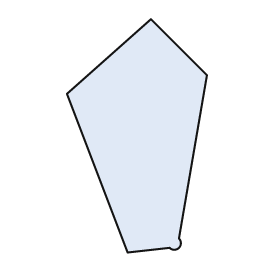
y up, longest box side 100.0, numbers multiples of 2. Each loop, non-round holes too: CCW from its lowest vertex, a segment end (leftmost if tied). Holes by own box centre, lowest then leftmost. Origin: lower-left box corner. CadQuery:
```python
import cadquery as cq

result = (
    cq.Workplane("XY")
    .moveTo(26.0, 0.0)
    .lineTo(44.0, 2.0)
    .threePointArc((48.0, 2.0), (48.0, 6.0))
    .lineTo(60.0, 76.0)
    .lineTo(36.0, 100.0)
    .lineTo(0.0, 68.0)
    .close()
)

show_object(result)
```